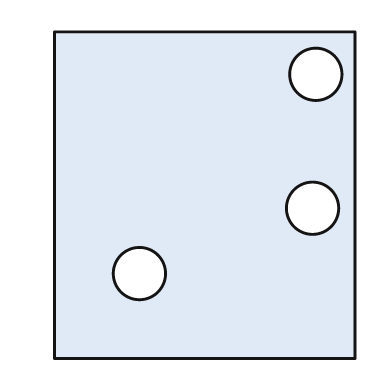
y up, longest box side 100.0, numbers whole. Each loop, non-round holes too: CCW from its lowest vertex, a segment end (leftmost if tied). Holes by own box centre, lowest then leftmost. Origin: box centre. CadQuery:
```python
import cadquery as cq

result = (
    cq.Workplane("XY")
    .moveTo(-46.0, -50.0)
    .lineTo(46.0, -50.0)
    .lineTo(46.0, 50.0)
    .lineTo(-46.0, 50.0)
    .close()
    .moveTo(-20.0, -24.0)
    .circle(8.0)
    .moveTo(33.0, -4.0)
    .circle(8.0)
    .moveTo(34.0, 37.0)
    .circle(8.0)
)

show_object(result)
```